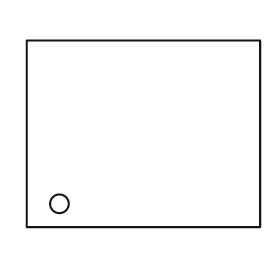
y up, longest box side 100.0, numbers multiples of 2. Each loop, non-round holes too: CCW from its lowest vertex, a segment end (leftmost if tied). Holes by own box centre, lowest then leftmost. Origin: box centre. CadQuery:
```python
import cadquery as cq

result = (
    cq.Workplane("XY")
    .moveTo(-50.0, -40.0)
    .lineTo(50.0, -40.0)
    .lineTo(50.0, 40.0)
    .lineTo(-50.0, 40.0)
    .close()
    .moveTo(-36.0, -30.0)
    .circle(4.0)
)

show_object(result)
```